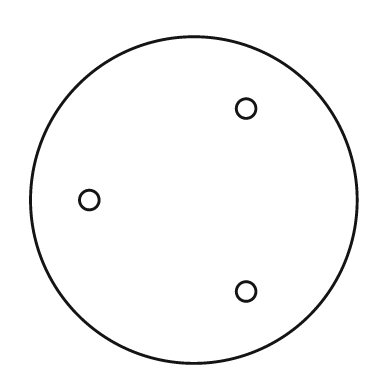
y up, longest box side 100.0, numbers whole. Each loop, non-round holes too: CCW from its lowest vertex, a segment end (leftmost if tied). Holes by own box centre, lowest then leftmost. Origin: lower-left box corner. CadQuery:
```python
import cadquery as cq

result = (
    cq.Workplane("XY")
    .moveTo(50.0, 50.0)
    .circle(50.0)
    .moveTo(66.0, 22.0)
    .circle(3.0)
    .moveTo(18.0, 50.0)
    .circle(3.0)
    .moveTo(66.0, 78.0)
    .circle(3.0)
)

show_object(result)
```